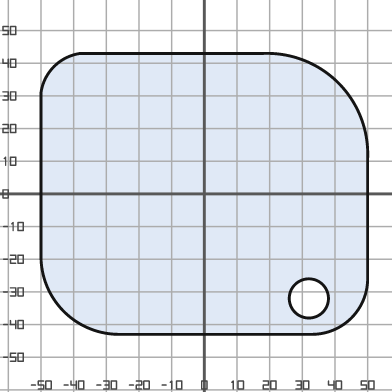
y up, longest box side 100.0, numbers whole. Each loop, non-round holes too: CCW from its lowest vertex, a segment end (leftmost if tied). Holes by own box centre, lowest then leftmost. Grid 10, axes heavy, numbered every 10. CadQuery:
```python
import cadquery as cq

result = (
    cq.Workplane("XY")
    .moveTo(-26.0, -43.0)
    .lineTo(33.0, -43.0)
    .threePointArc((45.0, -38.0), (50.0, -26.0))
    .lineTo(50.0, 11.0)
    .threePointArc((41.0, 34.0), (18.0, 43.0))
    .lineTo(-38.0, 43.0)
    .threePointArc((-46.0, 39.0), (-50.0, 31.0))
    .lineTo(-50.0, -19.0)
    .threePointArc((-43.0, -36.0), (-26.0, -43.0))
    .close()
    .moveTo(32.0, -32.0)
    .circle(6.0)
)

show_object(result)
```